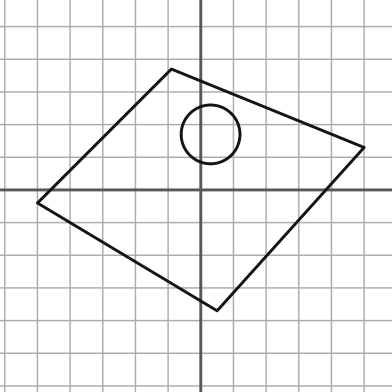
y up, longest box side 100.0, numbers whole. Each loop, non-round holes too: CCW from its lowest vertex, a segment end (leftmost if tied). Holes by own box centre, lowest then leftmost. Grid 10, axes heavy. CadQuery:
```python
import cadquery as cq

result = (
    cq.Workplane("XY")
    .moveTo(5.0, -37.0)
    .lineTo(50.0, 13.0)
    .lineTo(-9.0, 37.0)
    .lineTo(-50.0, -4.0)
    .close()
    .moveTo(3.0, 17.0)
    .circle(9.0)
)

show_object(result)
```